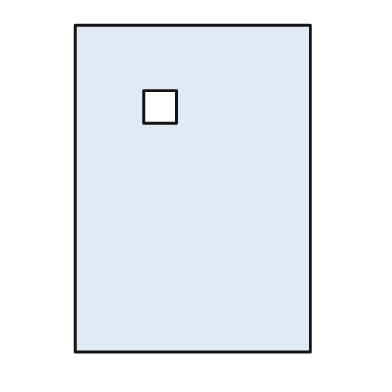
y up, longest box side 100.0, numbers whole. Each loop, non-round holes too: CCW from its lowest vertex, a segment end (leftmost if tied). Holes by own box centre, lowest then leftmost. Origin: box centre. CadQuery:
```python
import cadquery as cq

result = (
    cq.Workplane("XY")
    .moveTo(-36.0, -50.0)
    .lineTo(36.0, -50.0)
    .lineTo(36.0, 50.0)
    .lineTo(-36.0, 50.0)
    .close()
    .moveTo(-15.0, 20.0)
    .lineTo(-5.0, 20.0)
    .lineTo(-5.0, 30.0)
    .lineTo(-15.0, 30.0)
    .close()
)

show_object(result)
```